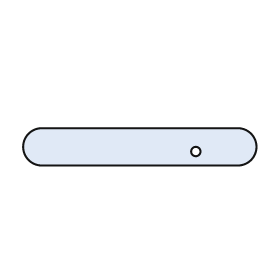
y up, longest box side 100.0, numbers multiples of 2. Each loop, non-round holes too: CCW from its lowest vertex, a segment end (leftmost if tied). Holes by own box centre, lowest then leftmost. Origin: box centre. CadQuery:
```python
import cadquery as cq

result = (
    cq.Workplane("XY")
    .moveTo(-42.0, -8.0)
    .lineTo(42.0, -8.0)
    .threePointArc((50.0, 0.0), (42.0, 8.0))
    .lineTo(-42.0, 8.0)
    .threePointArc((-50.0, 0.0), (-42.0, -8.0))
    .close()
    .moveTo(24.0, -2.0)
    .circle(2.0)
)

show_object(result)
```